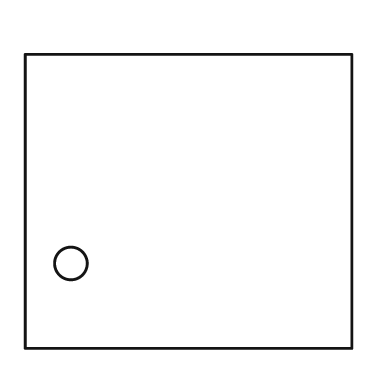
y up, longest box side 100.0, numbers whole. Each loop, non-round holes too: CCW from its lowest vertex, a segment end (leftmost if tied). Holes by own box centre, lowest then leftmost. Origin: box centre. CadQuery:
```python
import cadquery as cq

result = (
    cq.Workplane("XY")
    .moveTo(-50.0, -45.0)
    .lineTo(50.0, -45.0)
    .lineTo(50.0, 45.0)
    .lineTo(-50.0, 45.0)
    .close()
    .moveTo(-36.0, -19.0)
    .circle(5.0)
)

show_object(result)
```